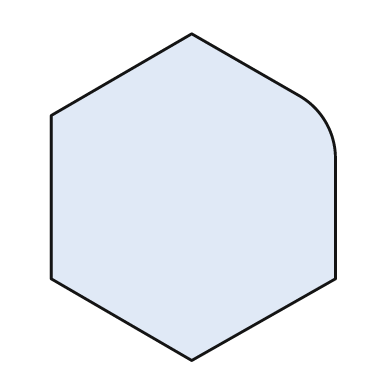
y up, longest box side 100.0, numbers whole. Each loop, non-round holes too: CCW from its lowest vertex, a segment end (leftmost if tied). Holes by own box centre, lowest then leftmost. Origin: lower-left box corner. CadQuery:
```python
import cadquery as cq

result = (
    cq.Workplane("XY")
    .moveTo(43.0, 0.0)
    .lineTo(87.0, 25.0)
    .lineTo(87.0, 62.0)
    .threePointArc((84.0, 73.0), (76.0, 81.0))
    .lineTo(43.0, 100.0)
    .lineTo(0.0, 75.0)
    .lineTo(0.0, 25.0)
    .close()
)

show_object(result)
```